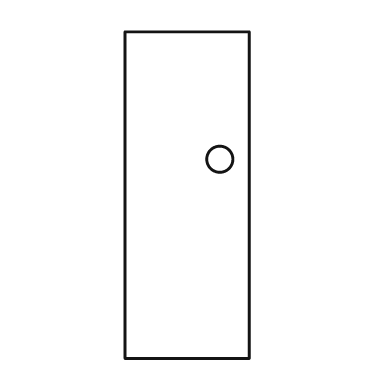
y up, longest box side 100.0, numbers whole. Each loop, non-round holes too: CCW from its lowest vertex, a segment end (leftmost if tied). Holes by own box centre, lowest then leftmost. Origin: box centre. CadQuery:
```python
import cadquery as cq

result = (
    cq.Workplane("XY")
    .moveTo(-19.0, -50.0)
    .lineTo(19.0, -50.0)
    .lineTo(19.0, 50.0)
    .lineTo(-19.0, 50.0)
    .close()
    .moveTo(10.0, 11.0)
    .circle(4.0)
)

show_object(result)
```